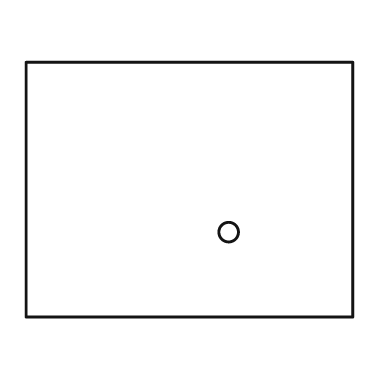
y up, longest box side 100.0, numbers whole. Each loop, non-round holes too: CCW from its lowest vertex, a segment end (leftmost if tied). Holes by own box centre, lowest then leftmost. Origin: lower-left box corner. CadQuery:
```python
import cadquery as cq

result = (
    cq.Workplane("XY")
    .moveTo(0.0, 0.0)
    .lineTo(100.0, 0.0)
    .lineTo(100.0, 78.0)
    .lineTo(0.0, 78.0)
    .close()
    .moveTo(62.0, 26.0)
    .circle(3.0)
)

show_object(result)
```